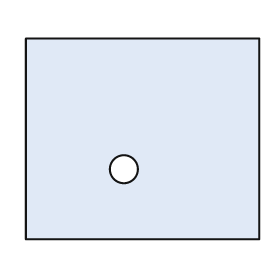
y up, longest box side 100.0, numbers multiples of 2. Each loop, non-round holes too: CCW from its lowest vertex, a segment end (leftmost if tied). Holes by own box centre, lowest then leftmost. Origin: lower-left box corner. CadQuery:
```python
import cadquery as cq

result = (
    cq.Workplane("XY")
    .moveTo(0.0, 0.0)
    .lineTo(100.0, 0.0)
    .lineTo(100.0, 86.0)
    .lineTo(0.0, 86.0)
    .close()
    .moveTo(42.0, 30.0)
    .circle(6.0)
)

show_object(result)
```